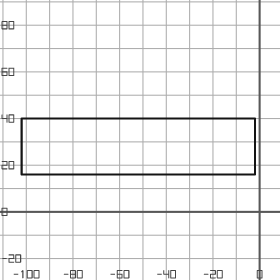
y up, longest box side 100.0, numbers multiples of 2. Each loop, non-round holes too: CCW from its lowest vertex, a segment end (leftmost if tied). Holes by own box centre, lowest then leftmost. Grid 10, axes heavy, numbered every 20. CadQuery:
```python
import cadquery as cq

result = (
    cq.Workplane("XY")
    .moveTo(-102.0, 16.0)
    .lineTo(-2.0, 16.0)
    .lineTo(-2.0, 40.0)
    .lineTo(-102.0, 40.0)
    .close()
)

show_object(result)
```